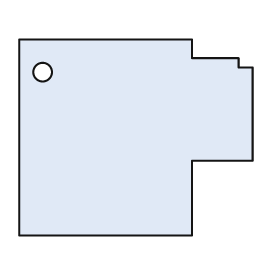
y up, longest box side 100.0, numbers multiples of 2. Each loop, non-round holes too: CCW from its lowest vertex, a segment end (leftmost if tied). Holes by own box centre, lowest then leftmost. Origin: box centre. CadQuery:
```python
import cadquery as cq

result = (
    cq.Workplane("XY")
    .moveTo(-50.0, -42.0)
    .lineTo(24.0, -42.0)
    .lineTo(24.0, -10.0)
    .lineTo(50.0, -10.0)
    .lineTo(50.0, 30.0)
    .lineTo(44.0, 30.0)
    .lineTo(44.0, 34.0)
    .lineTo(24.0, 34.0)
    .lineTo(24.0, 42.0)
    .lineTo(-50.0, 42.0)
    .close()
    .moveTo(-40.0, 28.0)
    .circle(4.0)
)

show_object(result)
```